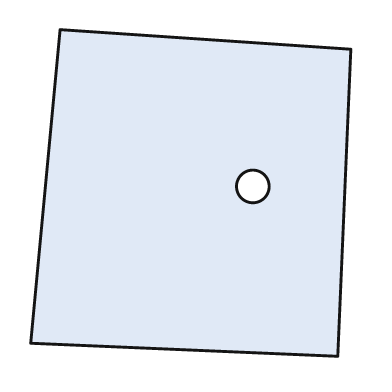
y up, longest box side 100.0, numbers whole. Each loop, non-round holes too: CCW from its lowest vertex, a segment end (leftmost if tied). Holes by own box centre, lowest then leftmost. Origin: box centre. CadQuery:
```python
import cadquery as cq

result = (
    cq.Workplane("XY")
    .moveTo(45.0, -50.0)
    .lineTo(49.0, 44.0)
    .lineTo(-40.0, 50.0)
    .lineTo(-49.0, -46.0)
    .close()
    .moveTo(19.0, 2.0)
    .circle(5.0)
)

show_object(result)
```